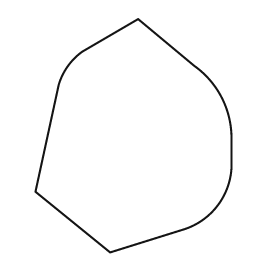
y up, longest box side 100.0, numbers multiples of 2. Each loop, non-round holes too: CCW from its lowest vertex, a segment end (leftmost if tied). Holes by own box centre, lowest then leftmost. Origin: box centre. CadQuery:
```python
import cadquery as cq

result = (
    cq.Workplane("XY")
    .moveTo(-10.0, -50.0)
    .lineTo(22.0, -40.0)
    .threePointArc((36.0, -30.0), (42.0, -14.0))
    .lineTo(42.0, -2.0)
    .threePointArc((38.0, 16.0), (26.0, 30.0))
    .lineTo(2.0, 50.0)
    .lineTo(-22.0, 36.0)
    .threePointArc((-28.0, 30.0), (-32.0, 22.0))
    .lineTo(-42.0, -24.0)
    .close()
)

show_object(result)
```